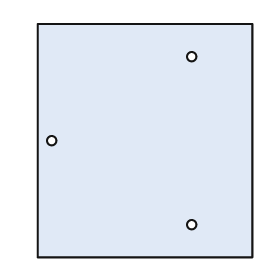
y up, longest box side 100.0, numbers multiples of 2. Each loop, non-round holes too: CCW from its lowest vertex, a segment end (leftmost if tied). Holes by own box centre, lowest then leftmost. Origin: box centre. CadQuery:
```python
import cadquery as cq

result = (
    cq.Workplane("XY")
    .moveTo(-46.0, -50.0)
    .lineTo(46.0, -50.0)
    .lineTo(46.0, 50.0)
    .lineTo(-46.0, 50.0)
    .close()
    .moveTo(20.0, -36.0)
    .circle(2.0)
    .moveTo(-40.0, 0.0)
    .circle(2.0)
    .moveTo(20.0, 36.0)
    .circle(2.0)
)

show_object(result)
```